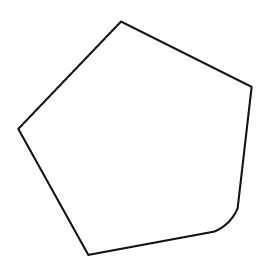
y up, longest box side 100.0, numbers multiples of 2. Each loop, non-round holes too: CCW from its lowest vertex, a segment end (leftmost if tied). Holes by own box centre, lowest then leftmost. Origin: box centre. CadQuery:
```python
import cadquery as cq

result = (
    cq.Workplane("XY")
    .moveTo(-20.0, -50.0)
    .lineTo(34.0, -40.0)
    .threePointArc((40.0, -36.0), (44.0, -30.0))
    .lineTo(50.0, 22.0)
    .lineTo(-6.0, 50.0)
    .lineTo(-50.0, 4.0)
    .close()
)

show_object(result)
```